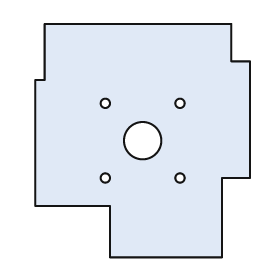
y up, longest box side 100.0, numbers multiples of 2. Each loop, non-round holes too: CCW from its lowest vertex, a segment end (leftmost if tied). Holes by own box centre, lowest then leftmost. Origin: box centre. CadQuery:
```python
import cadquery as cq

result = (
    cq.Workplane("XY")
    .moveTo(-14.0, -50.0)
    .lineTo(34.0, -50.0)
    .lineTo(34.0, -16.0)
    .lineTo(46.0, -16.0)
    .lineTo(46.0, 34.0)
    .lineTo(38.0, 34.0)
    .lineTo(38.0, 50.0)
    .lineTo(-42.0, 50.0)
    .lineTo(-42.0, 26.0)
    .lineTo(-46.0, 26.0)
    .lineTo(-46.0, -28.0)
    .lineTo(-14.0, -28.0)
    .close()
    .moveTo(-16.0, -16.0)
    .circle(2.0)
    .moveTo(16.0, -16.0)
    .circle(2.0)
    .moveTo(0.0, 0.0)
    .circle(8.0)
    .moveTo(-16.0, 16.0)
    .circle(2.0)
    .moveTo(16.0, 16.0)
    .circle(2.0)
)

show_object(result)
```